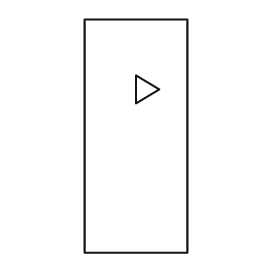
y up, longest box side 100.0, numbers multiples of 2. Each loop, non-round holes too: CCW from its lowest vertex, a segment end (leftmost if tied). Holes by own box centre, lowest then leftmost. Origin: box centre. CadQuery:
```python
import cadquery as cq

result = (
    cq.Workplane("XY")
    .moveTo(-22.0, -50.0)
    .lineTo(22.0, -50.0)
    .lineTo(22.0, 50.0)
    .lineTo(-22.0, 50.0)
    .close()
    .moveTo(0.0, 14.0)
    .lineTo(10.0, 20.0)
    .lineTo(0.0, 26.0)
    .close()
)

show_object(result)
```